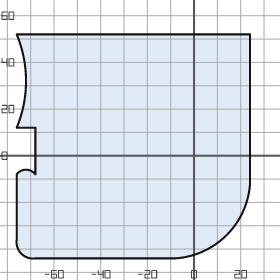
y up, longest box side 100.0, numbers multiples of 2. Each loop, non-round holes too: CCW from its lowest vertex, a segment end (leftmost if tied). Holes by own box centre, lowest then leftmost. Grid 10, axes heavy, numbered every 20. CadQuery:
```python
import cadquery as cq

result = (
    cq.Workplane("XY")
    .moveTo(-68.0, -44.0)
    .lineTo(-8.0, -44.0)
    .threePointArc((14.0, -34.0), (24.0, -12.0))
    .lineTo(24.0, 52.0)
    .lineTo(-76.0, 52.0)
    .threePointArc((-72.0, 32.0), (-76.0, 12.0))
    .lineTo(-68.0, 12.0)
    .lineTo(-68.0, -8.0)
    .threePointArc((-72.0, -6.0), (-76.0, -8.0))
    .lineTo(-76.0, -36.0)
    .threePointArc((-74.0, -42.0), (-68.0, -44.0))
    .close()
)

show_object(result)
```